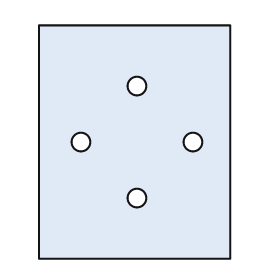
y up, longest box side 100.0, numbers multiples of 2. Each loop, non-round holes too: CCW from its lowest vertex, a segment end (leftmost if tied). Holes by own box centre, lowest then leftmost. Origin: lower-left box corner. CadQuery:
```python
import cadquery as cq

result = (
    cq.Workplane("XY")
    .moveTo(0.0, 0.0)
    .lineTo(82.0, 0.0)
    .lineTo(82.0, 100.0)
    .lineTo(0.0, 100.0)
    .close()
    .moveTo(42.0, 26.0)
    .circle(4.0)
    .moveTo(18.0, 50.0)
    .circle(4.0)
    .moveTo(66.0, 50.0)
    .circle(4.0)
    .moveTo(42.0, 74.0)
    .circle(4.0)
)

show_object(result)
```